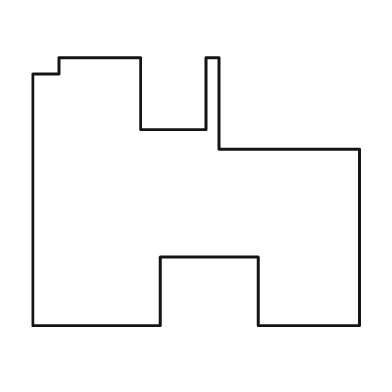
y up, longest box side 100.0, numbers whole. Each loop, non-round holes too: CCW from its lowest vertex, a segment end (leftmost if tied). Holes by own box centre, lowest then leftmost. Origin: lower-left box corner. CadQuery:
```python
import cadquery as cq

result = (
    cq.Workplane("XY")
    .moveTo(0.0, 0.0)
    .lineTo(39.0, 0.0)
    .lineTo(39.0, 21.0)
    .lineTo(69.0, 21.0)
    .lineTo(69.0, 0.0)
    .lineTo(100.0, 0.0)
    .lineTo(100.0, 54.0)
    .lineTo(57.0, 54.0)
    .lineTo(57.0, 82.0)
    .lineTo(53.0, 82.0)
    .lineTo(53.0, 60.0)
    .lineTo(33.0, 60.0)
    .lineTo(33.0, 82.0)
    .lineTo(8.0, 82.0)
    .lineTo(8.0, 77.0)
    .lineTo(0.0, 77.0)
    .close()
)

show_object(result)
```